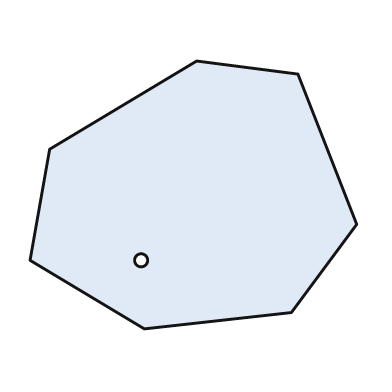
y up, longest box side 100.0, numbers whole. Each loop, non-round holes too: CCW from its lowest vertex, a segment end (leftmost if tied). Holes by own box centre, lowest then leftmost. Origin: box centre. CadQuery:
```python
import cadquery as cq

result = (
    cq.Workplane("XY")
    .moveTo(-15.0, -41.0)
    .lineTo(30.0, -36.0)
    .lineTo(50.0, -9.0)
    .lineTo(32.0, 37.0)
    .lineTo(1.0, 41.0)
    .lineTo(-44.0, 14.0)
    .lineTo(-50.0, -20.0)
    .close()
    .moveTo(-16.0, -20.0)
    .circle(2.0)
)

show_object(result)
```